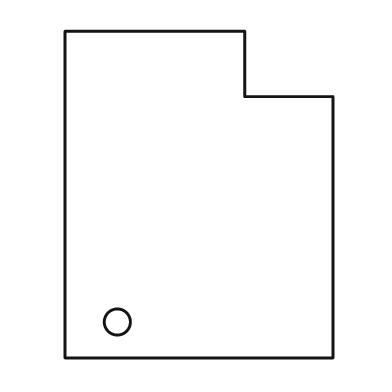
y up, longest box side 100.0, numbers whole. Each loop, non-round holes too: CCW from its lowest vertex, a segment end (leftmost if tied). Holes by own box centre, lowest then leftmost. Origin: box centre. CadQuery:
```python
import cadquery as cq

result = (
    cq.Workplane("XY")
    .moveTo(-41.0, -50.0)
    .lineTo(41.0, -50.0)
    .lineTo(41.0, 30.0)
    .lineTo(14.0, 30.0)
    .lineTo(14.0, 50.0)
    .lineTo(-41.0, 50.0)
    .close()
    .moveTo(-25.0, -39.0)
    .circle(4.0)
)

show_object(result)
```